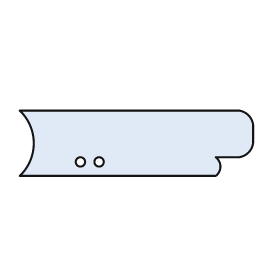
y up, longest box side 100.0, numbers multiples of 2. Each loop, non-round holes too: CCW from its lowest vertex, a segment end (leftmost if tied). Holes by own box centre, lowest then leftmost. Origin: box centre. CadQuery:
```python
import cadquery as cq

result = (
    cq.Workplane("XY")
    .moveTo(-50.0, -14.0)
    .lineTo(34.0, -14.0)
    .threePointArc((36.0, -10.0), (34.0, -6.0))
    .lineTo(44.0, -6.0)
    .threePointArc((48.0, -4.0), (50.0, 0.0))
    .lineTo(50.0, 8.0)
    .threePointArc((48.0, 12.0), (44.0, 14.0))
    .lineTo(-50.0, 14.0)
    .threePointArc((-44.0, 0.0), (-50.0, -14.0))
    .close()
    .moveTo(-24.0, -8.0)
    .circle(2.0)
    .moveTo(-16.0, -8.0)
    .circle(2.0)
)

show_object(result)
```